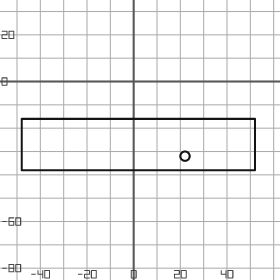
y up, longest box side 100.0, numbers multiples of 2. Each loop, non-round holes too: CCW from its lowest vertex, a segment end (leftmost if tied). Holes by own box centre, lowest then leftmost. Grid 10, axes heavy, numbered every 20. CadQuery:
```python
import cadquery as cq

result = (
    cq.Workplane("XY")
    .moveTo(-48.0, -38.0)
    .lineTo(52.0, -38.0)
    .lineTo(52.0, -16.0)
    .lineTo(-48.0, -16.0)
    .close()
    .moveTo(22.0, -32.0)
    .circle(2.0)
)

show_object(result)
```